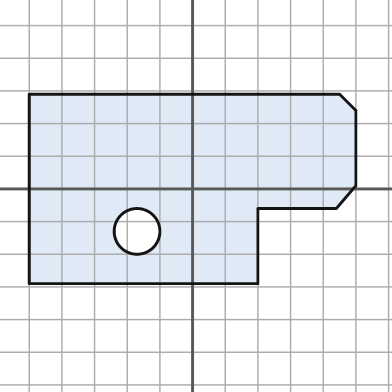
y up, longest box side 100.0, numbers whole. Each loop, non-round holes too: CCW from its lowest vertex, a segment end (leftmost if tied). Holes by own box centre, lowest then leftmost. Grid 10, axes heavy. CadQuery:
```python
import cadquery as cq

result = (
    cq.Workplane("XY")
    .moveTo(-50.0, -29.0)
    .lineTo(20.0, -29.0)
    .lineTo(20.0, -6.0)
    .lineTo(44.0, -6.0)
    .lineTo(50.0, 1.0)
    .lineTo(50.0, 24.0)
    .lineTo(45.0, 29.0)
    .lineTo(-50.0, 29.0)
    .close()
    .moveTo(-17.0, -13.0)
    .circle(7.0)
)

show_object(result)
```